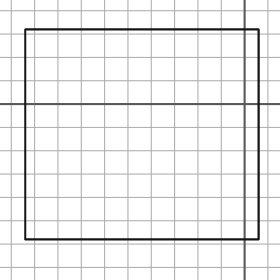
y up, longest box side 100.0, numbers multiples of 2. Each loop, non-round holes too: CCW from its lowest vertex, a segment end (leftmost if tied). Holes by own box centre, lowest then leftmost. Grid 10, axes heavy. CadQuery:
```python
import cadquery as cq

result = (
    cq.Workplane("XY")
    .moveTo(-94.0, -58.0)
    .lineTo(6.0, -58.0)
    .lineTo(6.0, 32.0)
    .lineTo(-94.0, 32.0)
    .close()
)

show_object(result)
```